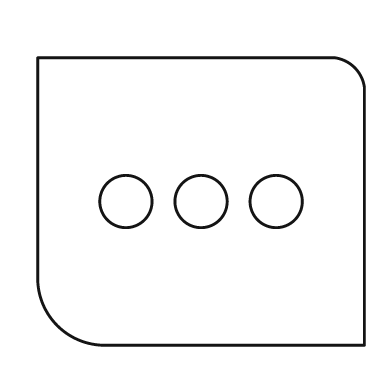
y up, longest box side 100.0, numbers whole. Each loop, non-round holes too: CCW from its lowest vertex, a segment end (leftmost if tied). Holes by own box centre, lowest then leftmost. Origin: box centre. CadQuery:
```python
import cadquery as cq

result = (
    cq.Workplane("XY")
    .moveTo(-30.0, -44.0)
    .lineTo(50.0, -44.0)
    .lineTo(50.0, 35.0)
    .threePointArc((47.0, 41.0), (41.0, 44.0))
    .lineTo(-50.0, 44.0)
    .lineTo(-50.0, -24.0)
    .threePointArc((-44.0, -38.0), (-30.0, -44.0))
    .close()
    .moveTo(-23.0, 0.0)
    .circle(8.0)
    .moveTo(0.0, 0.0)
    .circle(8.0)
    .moveTo(23.0, 0.0)
    .circle(8.0)
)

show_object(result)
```